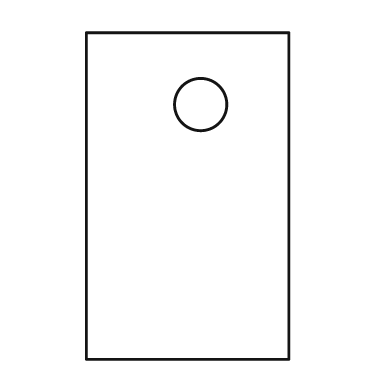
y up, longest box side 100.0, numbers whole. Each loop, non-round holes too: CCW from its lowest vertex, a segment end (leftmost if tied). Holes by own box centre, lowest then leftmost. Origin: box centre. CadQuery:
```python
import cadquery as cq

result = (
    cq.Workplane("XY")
    .moveTo(-31.0, -50.0)
    .lineTo(31.0, -50.0)
    .lineTo(31.0, 50.0)
    .lineTo(-31.0, 50.0)
    .close()
    .moveTo(4.0, 28.0)
    .circle(8.0)
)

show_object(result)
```